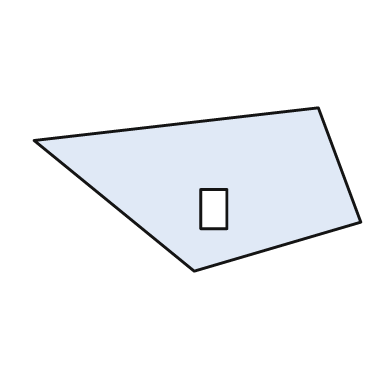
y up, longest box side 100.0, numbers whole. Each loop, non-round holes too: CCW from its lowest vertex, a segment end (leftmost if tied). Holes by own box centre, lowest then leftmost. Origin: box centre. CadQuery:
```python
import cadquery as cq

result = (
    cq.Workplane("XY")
    .moveTo(-1.0, -25.0)
    .lineTo(50.0, -10.0)
    .lineTo(37.0, 25.0)
    .lineTo(-50.0, 15.0)
    .close()
    .moveTo(1.0, -12.0)
    .lineTo(9.0, -12.0)
    .lineTo(9.0, 0.0)
    .lineTo(1.0, 0.0)
    .close()
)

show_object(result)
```